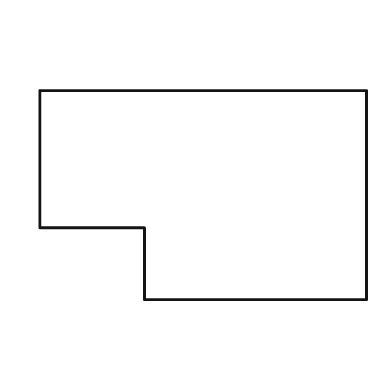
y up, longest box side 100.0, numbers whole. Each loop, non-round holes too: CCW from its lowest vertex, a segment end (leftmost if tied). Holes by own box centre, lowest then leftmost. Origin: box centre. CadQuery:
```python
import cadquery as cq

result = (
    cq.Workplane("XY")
    .moveTo(-18.0, -32.0)
    .lineTo(50.0, -32.0)
    .lineTo(50.0, 32.0)
    .lineTo(-50.0, 32.0)
    .lineTo(-50.0, -10.0)
    .lineTo(-18.0, -10.0)
    .close()
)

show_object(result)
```